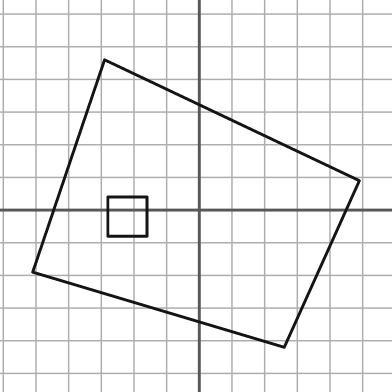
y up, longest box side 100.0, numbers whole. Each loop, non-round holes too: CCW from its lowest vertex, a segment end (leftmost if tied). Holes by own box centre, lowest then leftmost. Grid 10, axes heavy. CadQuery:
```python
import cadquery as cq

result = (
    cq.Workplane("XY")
    .moveTo(26.0, -42.0)
    .lineTo(49.0, 9.0)
    .lineTo(-29.0, 46.0)
    .lineTo(-51.0, -19.0)
    .close()
    .moveTo(-28.0, -8.0)
    .lineTo(-16.0, -8.0)
    .lineTo(-16.0, 4.0)
    .lineTo(-28.0, 4.0)
    .close()
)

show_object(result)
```